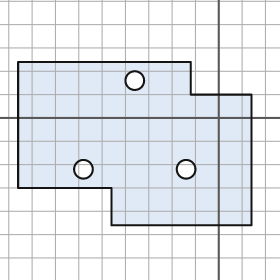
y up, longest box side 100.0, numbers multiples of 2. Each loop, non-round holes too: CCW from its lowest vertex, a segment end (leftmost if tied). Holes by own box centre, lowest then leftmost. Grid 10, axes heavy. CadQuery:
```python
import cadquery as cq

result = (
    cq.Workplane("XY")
    .moveTo(-46.0, -46.0)
    .lineTo(14.0, -46.0)
    .lineTo(14.0, 10.0)
    .lineTo(-12.0, 10.0)
    .lineTo(-12.0, 24.0)
    .lineTo(-86.0, 24.0)
    .lineTo(-86.0, -30.0)
    .lineTo(-46.0, -30.0)
    .close()
    .moveTo(-58.0, -22.0)
    .circle(4.0)
    .moveTo(-14.0, -22.0)
    .circle(4.0)
    .moveTo(-36.0, 16.0)
    .circle(4.0)
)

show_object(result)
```